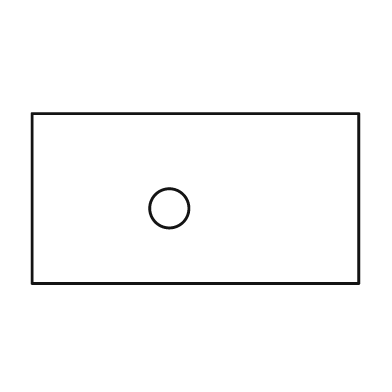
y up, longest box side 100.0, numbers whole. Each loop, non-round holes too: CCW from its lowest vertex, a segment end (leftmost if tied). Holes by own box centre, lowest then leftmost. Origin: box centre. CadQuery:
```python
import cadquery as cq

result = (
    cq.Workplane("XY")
    .moveTo(-50.0, -26.0)
    .lineTo(50.0, -26.0)
    .lineTo(50.0, 26.0)
    .lineTo(-50.0, 26.0)
    .close()
    .moveTo(-8.0, -3.0)
    .circle(6.0)
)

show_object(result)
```